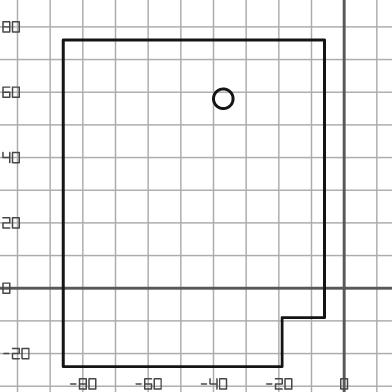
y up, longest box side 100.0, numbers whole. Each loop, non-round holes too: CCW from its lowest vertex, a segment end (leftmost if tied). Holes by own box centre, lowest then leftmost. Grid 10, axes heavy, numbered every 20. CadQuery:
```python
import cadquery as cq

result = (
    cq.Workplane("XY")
    .moveTo(-86.0, -24.0)
    .lineTo(-19.0, -24.0)
    .lineTo(-19.0, -9.0)
    .lineTo(-6.0, -9.0)
    .lineTo(-6.0, 76.0)
    .lineTo(-86.0, 76.0)
    .close()
    .moveTo(-37.0, 58.0)
    .circle(3.0)
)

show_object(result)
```